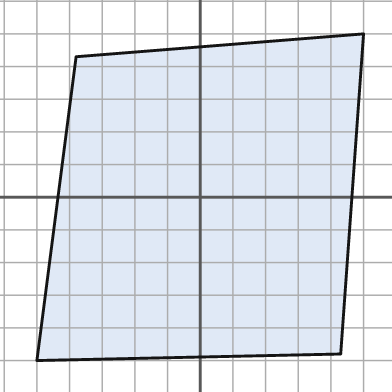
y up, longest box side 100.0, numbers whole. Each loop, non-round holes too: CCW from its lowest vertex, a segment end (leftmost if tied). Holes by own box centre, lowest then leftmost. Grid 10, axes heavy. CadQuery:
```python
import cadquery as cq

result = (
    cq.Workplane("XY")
    .moveTo(-50.0, -50.0)
    .lineTo(43.0, -48.0)
    .lineTo(50.0, 50.0)
    .lineTo(-38.0, 43.0)
    .close()
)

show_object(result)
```